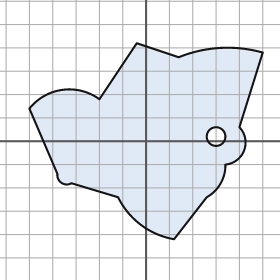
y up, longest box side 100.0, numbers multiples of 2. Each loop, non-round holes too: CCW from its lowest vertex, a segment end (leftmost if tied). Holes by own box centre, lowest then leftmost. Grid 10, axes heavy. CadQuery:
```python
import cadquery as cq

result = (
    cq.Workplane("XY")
    .moveTo(12.0, -42.0)
    .lineTo(26.0, -24.0)
    .threePointArc((32.0, -18.0), (34.0, -10.0))
    .threePointArc((42.0, -4.0), (40.0, 6.0))
    .lineTo(50.0, 38.0)
    .threePointArc((32.0, 40.0), (14.0, 36.0))
    .lineTo(-4.0, 42.0)
    .lineTo(-20.0, 18.0)
    .threePointArc((-36.0, 22.0), (-50.0, 14.0))
    .lineTo(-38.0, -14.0)
    .threePointArc((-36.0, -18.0), (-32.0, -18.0))
    .lineTo(-12.0, -24.0)
    .threePointArc((-2.0, -36.0), (12.0, -42.0))
    .close()
    .moveTo(30.0, 2.0)
    .circle(4.0)
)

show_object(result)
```